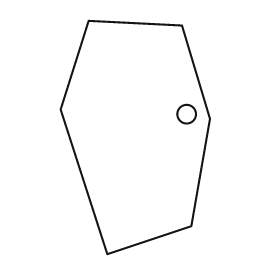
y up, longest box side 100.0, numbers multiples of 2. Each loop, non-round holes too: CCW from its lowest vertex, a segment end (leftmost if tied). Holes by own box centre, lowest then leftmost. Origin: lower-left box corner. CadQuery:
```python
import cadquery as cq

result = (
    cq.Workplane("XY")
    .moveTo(20.0, 0.0)
    .lineTo(56.0, 12.0)
    .lineTo(64.0, 58.0)
    .lineTo(52.0, 98.0)
    .lineTo(12.0, 100.0)
    .lineTo(0.0, 62.0)
    .close()
    .moveTo(54.0, 60.0)
    .circle(4.0)
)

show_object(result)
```